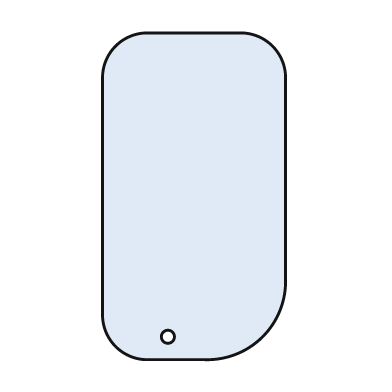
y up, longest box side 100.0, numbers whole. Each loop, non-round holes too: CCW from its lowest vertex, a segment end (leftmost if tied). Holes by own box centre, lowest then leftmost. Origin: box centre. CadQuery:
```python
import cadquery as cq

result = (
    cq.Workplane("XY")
    .moveTo(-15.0, -50.0)
    .lineTo(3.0, -50.0)
    .threePointArc((21.0, -43.0), (28.0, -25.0))
    .lineTo(28.0, 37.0)
    .threePointArc((24.0, 46.0), (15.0, 50.0))
    .lineTo(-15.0, 50.0)
    .threePointArc((-24.0, 46.0), (-28.0, 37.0))
    .lineTo(-28.0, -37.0)
    .threePointArc((-24.0, -46.0), (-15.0, -50.0))
    .close()
    .moveTo(-8.0, -43.0)
    .circle(2.0)
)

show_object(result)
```